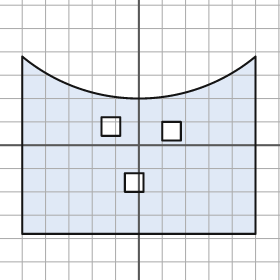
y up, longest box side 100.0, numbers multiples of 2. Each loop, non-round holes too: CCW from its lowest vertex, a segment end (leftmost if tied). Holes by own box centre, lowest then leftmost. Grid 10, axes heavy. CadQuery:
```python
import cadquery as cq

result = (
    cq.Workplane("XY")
    .moveTo(-50.0, -38.0)
    .lineTo(50.0, -38.0)
    .lineTo(50.0, 38.0)
    .threePointArc((0.0, 20.0), (-50.0, 38.0))
    .close()
    .moveTo(-6.0, -20.0)
    .lineTo(2.0, -20.0)
    .lineTo(2.0, -12.0)
    .lineTo(-6.0, -12.0)
    .close()
    .moveTo(10.0, 2.0)
    .lineTo(18.0, 2.0)
    .lineTo(18.0, 10.0)
    .lineTo(10.0, 10.0)
    .close()
    .moveTo(-16.0, 4.0)
    .lineTo(-8.0, 4.0)
    .lineTo(-8.0, 12.0)
    .lineTo(-16.0, 12.0)
    .close()
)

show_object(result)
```